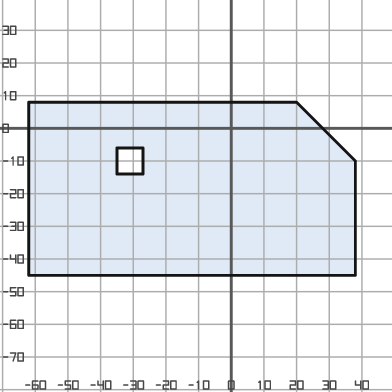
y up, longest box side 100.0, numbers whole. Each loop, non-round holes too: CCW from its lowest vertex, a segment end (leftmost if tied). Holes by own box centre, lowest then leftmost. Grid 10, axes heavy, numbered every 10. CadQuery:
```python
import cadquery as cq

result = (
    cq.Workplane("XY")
    .moveTo(-62.0, -45.0)
    .lineTo(38.0, -45.0)
    .lineTo(38.0, -10.0)
    .lineTo(20.0, 8.0)
    .lineTo(-62.0, 8.0)
    .close()
    .moveTo(-35.0, -14.0)
    .lineTo(-27.0, -14.0)
    .lineTo(-27.0, -6.0)
    .lineTo(-35.0, -6.0)
    .close()
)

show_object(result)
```